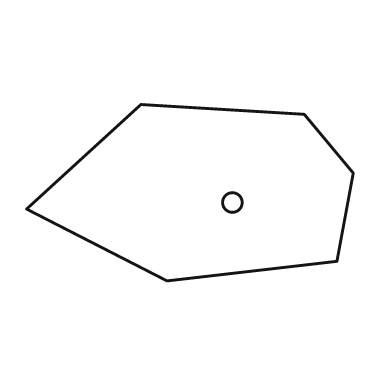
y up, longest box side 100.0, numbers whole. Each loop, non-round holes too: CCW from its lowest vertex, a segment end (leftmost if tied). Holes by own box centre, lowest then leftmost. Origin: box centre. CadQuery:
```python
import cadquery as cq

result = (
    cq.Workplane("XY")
    .moveTo(-7.0, -27.0)
    .lineTo(45.0, -21.0)
    .lineTo(50.0, 6.0)
    .lineTo(35.0, 24.0)
    .lineTo(-15.0, 27.0)
    .lineTo(-50.0, -5.0)
    .close()
    .moveTo(13.0, -3.0)
    .circle(3.0)
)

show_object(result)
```